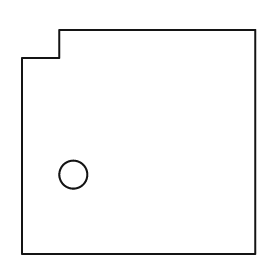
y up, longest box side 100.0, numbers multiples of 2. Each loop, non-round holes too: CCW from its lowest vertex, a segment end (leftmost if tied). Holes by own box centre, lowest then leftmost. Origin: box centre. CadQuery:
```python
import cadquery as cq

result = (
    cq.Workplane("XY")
    .moveTo(-50.0, -48.0)
    .lineTo(50.0, -48.0)
    .lineTo(50.0, 48.0)
    .lineTo(-34.0, 48.0)
    .lineTo(-34.0, 36.0)
    .lineTo(-50.0, 36.0)
    .close()
    .moveTo(-28.0, -14.0)
    .circle(6.0)
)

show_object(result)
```